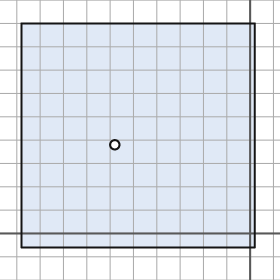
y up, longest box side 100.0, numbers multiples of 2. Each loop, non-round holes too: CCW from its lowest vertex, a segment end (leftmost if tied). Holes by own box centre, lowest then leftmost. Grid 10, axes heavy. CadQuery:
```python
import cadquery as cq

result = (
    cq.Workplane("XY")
    .moveTo(-98.0, -6.0)
    .lineTo(2.0, -6.0)
    .lineTo(2.0, 90.0)
    .lineTo(-98.0, 90.0)
    .close()
    .moveTo(-58.0, 38.0)
    .circle(2.0)
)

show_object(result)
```